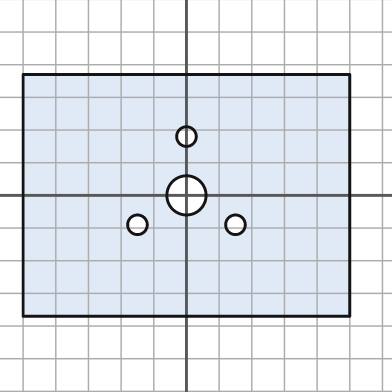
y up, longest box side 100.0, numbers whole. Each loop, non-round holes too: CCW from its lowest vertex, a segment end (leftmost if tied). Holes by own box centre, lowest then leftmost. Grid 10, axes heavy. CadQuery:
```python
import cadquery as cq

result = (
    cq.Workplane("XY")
    .moveTo(-50.0, -37.0)
    .lineTo(50.0, -37.0)
    .lineTo(50.0, 37.0)
    .lineTo(-50.0, 37.0)
    .close()
    .moveTo(-15.0, -9.0)
    .circle(3.0)
    .moveTo(15.0, -9.0)
    .circle(3.0)
    .moveTo(0.0, 0.0)
    .circle(6.0)
    .moveTo(0.0, 18.0)
    .circle(3.0)
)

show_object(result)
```